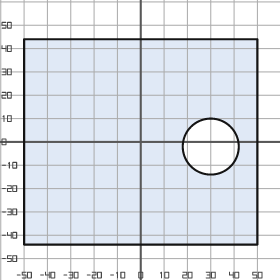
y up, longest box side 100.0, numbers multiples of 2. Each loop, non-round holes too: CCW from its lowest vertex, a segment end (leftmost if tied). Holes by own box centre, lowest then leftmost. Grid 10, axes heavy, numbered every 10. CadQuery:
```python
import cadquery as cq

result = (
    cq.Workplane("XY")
    .moveTo(-50.0, -44.0)
    .lineTo(50.0, -44.0)
    .lineTo(50.0, 44.0)
    .lineTo(-50.0, 44.0)
    .close()
    .moveTo(30.0, -2.0)
    .circle(12.0)
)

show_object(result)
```